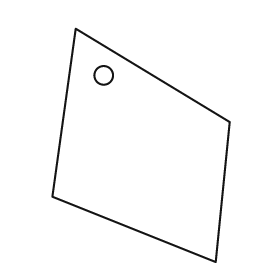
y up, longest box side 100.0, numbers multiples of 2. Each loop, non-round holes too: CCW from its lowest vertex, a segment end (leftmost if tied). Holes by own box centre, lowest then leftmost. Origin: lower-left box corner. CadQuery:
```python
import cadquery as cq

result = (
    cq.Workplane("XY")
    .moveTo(70.0, 0.0)
    .lineTo(76.0, 60.0)
    .lineTo(10.0, 100.0)
    .lineTo(0.0, 28.0)
    .close()
    .moveTo(22.0, 80.0)
    .circle(4.0)
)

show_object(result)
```